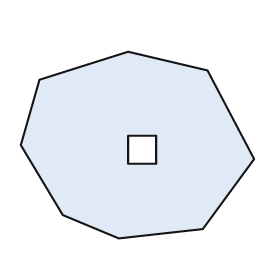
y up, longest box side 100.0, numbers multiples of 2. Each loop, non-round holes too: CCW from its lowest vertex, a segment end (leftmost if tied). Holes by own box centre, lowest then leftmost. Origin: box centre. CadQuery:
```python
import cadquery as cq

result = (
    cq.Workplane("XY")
    .moveTo(-8.0, -40.0)
    .lineTo(28.0, -36.0)
    .lineTo(50.0, -6.0)
    .lineTo(30.0, 32.0)
    .lineTo(-4.0, 40.0)
    .lineTo(-42.0, 28.0)
    .lineTo(-50.0, 0.0)
    .lineTo(-32.0, -30.0)
    .close()
    .moveTo(-4.0, -8.0)
    .lineTo(8.0, -8.0)
    .lineTo(8.0, 4.0)
    .lineTo(-4.0, 4.0)
    .close()
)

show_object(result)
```